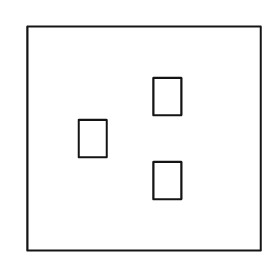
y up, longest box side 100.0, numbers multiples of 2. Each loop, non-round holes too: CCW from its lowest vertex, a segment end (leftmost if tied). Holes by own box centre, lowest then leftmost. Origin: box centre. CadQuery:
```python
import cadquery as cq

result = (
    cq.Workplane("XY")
    .moveTo(-50.0, -48.0)
    .lineTo(50.0, -48.0)
    .lineTo(50.0, 48.0)
    .lineTo(-50.0, 48.0)
    .close()
    .moveTo(4.0, -26.0)
    .lineTo(16.0, -26.0)
    .lineTo(16.0, -10.0)
    .lineTo(4.0, -10.0)
    .close()
    .moveTo(-28.0, -8.0)
    .lineTo(-16.0, -8.0)
    .lineTo(-16.0, 8.0)
    .lineTo(-28.0, 8.0)
    .close()
    .moveTo(4.0, 10.0)
    .lineTo(16.0, 10.0)
    .lineTo(16.0, 26.0)
    .lineTo(4.0, 26.0)
    .close()
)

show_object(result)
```